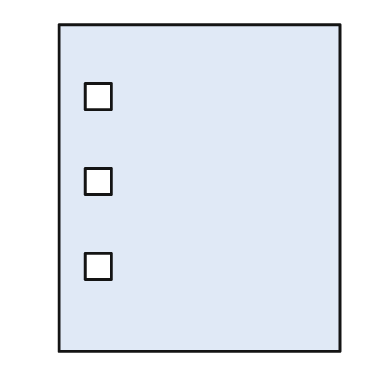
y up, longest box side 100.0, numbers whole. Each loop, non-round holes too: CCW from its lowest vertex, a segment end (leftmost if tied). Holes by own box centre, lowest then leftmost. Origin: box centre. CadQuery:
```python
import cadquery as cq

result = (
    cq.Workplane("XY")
    .moveTo(-43.0, -50.0)
    .lineTo(43.0, -50.0)
    .lineTo(43.0, 50.0)
    .lineTo(-43.0, 50.0)
    .close()
    .moveTo(-35.0, -28.0)
    .lineTo(-27.0, -28.0)
    .lineTo(-27.0, -20.0)
    .lineTo(-35.0, -20.0)
    .close()
    .moveTo(-35.0, -2.0)
    .lineTo(-27.0, -2.0)
    .lineTo(-27.0, 6.0)
    .lineTo(-35.0, 6.0)
    .close()
    .moveTo(-35.0, 24.0)
    .lineTo(-27.0, 24.0)
    .lineTo(-27.0, 32.0)
    .lineTo(-35.0, 32.0)
    .close()
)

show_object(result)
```